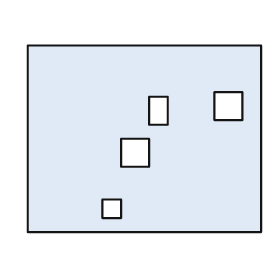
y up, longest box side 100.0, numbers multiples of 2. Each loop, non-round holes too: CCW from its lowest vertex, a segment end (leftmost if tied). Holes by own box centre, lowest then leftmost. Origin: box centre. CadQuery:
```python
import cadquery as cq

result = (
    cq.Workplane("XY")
    .moveTo(-50.0, -40.0)
    .lineTo(50.0, -40.0)
    .lineTo(50.0, 40.0)
    .lineTo(-50.0, 40.0)
    .close()
    .moveTo(-18.0, -34.0)
    .lineTo(-10.0, -34.0)
    .lineTo(-10.0, -26.0)
    .lineTo(-18.0, -26.0)
    .close()
    .moveTo(-10.0, -12.0)
    .lineTo(2.0, -12.0)
    .lineTo(2.0, 0.0)
    .lineTo(-10.0, 0.0)
    .close()
    .moveTo(2.0, 6.0)
    .lineTo(10.0, 6.0)
    .lineTo(10.0, 18.0)
    .lineTo(2.0, 18.0)
    .close()
    .moveTo(30.0, 8.0)
    .lineTo(42.0, 8.0)
    .lineTo(42.0, 20.0)
    .lineTo(30.0, 20.0)
    .close()
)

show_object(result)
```